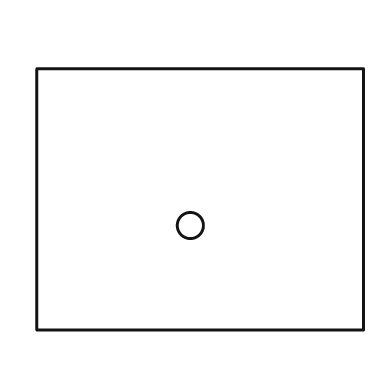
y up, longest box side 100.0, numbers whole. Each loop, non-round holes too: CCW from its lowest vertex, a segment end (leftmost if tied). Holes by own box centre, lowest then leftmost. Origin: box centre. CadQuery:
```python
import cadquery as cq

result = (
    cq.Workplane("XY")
    .moveTo(-50.0, -40.0)
    .lineTo(50.0, -40.0)
    .lineTo(50.0, 40.0)
    .lineTo(-50.0, 40.0)
    .close()
    .moveTo(-3.0, -8.0)
    .circle(4.0)
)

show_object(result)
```